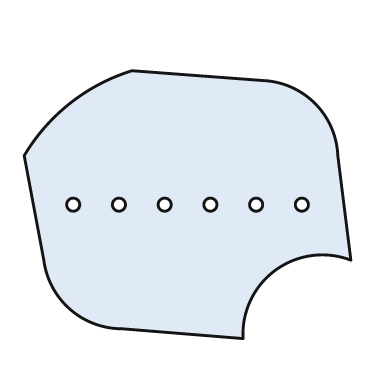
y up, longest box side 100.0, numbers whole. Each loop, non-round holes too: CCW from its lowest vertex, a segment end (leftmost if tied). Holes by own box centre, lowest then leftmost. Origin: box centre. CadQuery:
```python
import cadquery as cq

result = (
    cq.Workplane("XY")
    .moveTo(17.0, -41.0)
    .threePointArc((27.0, -20.0), (50.0, -17.0))
    .lineTo(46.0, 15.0)
    .threePointArc((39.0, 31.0), (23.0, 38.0))
    .lineTo(-17.0, 41.0)
    .threePointArc((-36.0, 31.0), (-50.0, 15.0))
    .lineTo(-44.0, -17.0)
    .threePointArc((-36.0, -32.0), (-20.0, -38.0))
    .close()
    .moveTo(-35.0, 0.0)
    .circle(2.0)
    .moveTo(-21.0, 0.0)
    .circle(2.0)
    .moveTo(-7.0, 0.0)
    .circle(2.0)
    .moveTo(7.0, 0.0)
    .circle(2.0)
    .moveTo(21.0, 0.0)
    .circle(2.0)
    .moveTo(35.0, 0.0)
    .circle(2.0)
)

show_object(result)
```